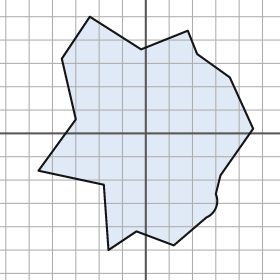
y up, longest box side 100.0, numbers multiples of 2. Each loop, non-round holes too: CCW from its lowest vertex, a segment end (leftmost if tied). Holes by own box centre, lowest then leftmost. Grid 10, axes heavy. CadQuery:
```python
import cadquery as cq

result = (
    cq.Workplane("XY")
    .moveTo(-16.0, -50.0)
    .lineTo(-4.0, -42.0)
    .lineTo(12.0, -48.0)
    .lineTo(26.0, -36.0)
    .threePointArc((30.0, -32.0), (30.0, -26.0))
    .lineTo(32.0, -18.0)
    .lineTo(46.0, 2.0)
    .lineTo(36.0, 24.0)
    .lineTo(22.0, 34.0)
    .lineTo(18.0, 44.0)
    .lineTo(-2.0, 36.0)
    .lineTo(-24.0, 50.0)
    .lineTo(-36.0, 32.0)
    .lineTo(-30.0, 6.0)
    .lineTo(-46.0, -16.0)
    .lineTo(-18.0, -22.0)
    .close()
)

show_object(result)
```